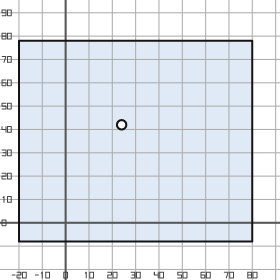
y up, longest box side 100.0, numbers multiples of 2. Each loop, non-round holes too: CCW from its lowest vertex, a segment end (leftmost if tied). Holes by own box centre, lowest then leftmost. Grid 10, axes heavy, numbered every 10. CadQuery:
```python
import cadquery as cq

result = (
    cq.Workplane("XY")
    .moveTo(-20.0, -8.0)
    .lineTo(80.0, -8.0)
    .lineTo(80.0, 78.0)
    .lineTo(-20.0, 78.0)
    .close()
    .moveTo(24.0, 42.0)
    .circle(2.0)
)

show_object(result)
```